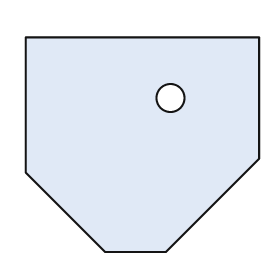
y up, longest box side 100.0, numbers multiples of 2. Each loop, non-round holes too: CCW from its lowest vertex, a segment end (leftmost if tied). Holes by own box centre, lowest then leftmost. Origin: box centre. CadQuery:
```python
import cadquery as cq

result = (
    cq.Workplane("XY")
    .moveTo(-16.0, -46.0)
    .lineTo(10.0, -46.0)
    .lineTo(50.0, -6.0)
    .lineTo(50.0, 46.0)
    .lineTo(-50.0, 46.0)
    .lineTo(-50.0, -12.0)
    .close()
    .moveTo(12.0, 20.0)
    .circle(6.0)
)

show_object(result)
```